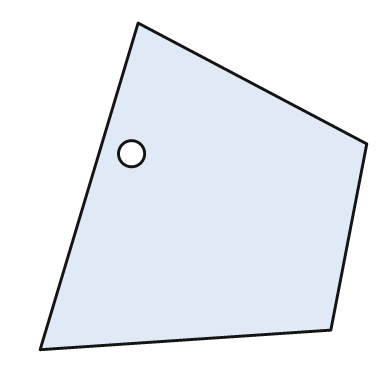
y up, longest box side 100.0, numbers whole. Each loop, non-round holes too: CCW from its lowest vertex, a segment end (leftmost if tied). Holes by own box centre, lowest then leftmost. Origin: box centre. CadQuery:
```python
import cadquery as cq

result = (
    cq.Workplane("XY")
    .moveTo(-50.0, -50.0)
    .lineTo(39.0, -44.0)
    .lineTo(50.0, 13.0)
    .lineTo(-20.0, 50.0)
    .close()
    .moveTo(-22.0, 10.0)
    .circle(4.0)
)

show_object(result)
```